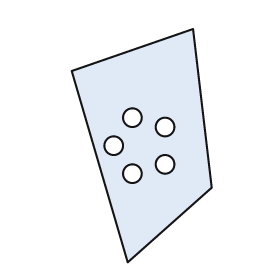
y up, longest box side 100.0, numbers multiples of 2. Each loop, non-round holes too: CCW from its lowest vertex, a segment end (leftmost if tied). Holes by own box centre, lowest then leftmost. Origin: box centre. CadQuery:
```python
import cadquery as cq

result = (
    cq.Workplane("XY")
    .moveTo(-6.0, -50.0)
    .lineTo(30.0, -18.0)
    .lineTo(22.0, 50.0)
    .lineTo(-30.0, 32.0)
    .close()
    .moveTo(-4.0, -12.0)
    .circle(4.0)
    .moveTo(10.0, -8.0)
    .circle(4.0)
    .moveTo(-12.0, 0.0)
    .circle(4.0)
    .moveTo(10.0, 8.0)
    .circle(4.0)
    .moveTo(-4.0, 12.0)
    .circle(4.0)
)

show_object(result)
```